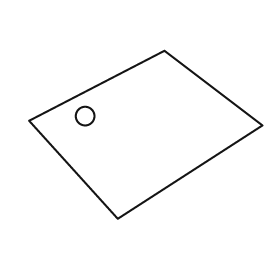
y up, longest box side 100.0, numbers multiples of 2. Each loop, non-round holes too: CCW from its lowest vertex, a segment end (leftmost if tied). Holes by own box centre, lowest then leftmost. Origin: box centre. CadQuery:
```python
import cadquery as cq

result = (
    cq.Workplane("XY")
    .moveTo(-12.0, -36.0)
    .lineTo(50.0, 4.0)
    .lineTo(8.0, 36.0)
    .lineTo(-50.0, 6.0)
    .close()
    .moveTo(-26.0, 8.0)
    .circle(4.0)
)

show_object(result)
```